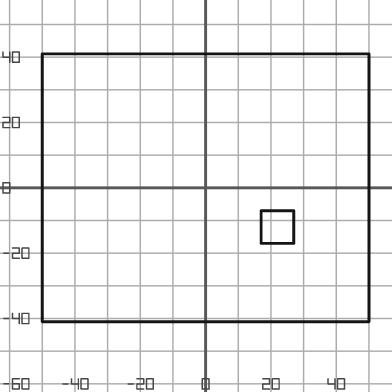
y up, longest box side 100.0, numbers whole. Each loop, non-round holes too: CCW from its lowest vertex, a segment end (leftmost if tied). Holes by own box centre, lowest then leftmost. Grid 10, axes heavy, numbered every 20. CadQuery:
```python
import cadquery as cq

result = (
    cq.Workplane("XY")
    .moveTo(-50.0, -41.0)
    .lineTo(50.0, -41.0)
    .lineTo(50.0, 41.0)
    .lineTo(-50.0, 41.0)
    .close()
    .moveTo(17.0, -17.0)
    .lineTo(27.0, -17.0)
    .lineTo(27.0, -7.0)
    .lineTo(17.0, -7.0)
    .close()
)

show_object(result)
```